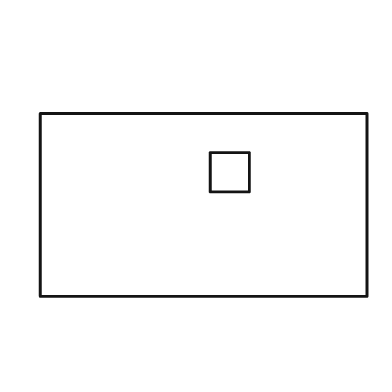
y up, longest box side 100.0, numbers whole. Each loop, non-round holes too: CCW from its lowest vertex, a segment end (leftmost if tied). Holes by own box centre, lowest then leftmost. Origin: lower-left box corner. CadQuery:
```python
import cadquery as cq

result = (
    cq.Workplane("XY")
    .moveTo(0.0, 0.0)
    .lineTo(100.0, 0.0)
    .lineTo(100.0, 56.0)
    .lineTo(0.0, 56.0)
    .close()
    .moveTo(52.0, 32.0)
    .lineTo(64.0, 32.0)
    .lineTo(64.0, 44.0)
    .lineTo(52.0, 44.0)
    .close()
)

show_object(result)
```